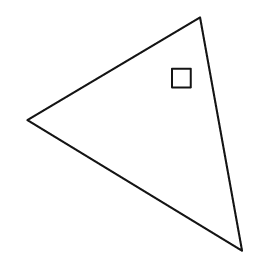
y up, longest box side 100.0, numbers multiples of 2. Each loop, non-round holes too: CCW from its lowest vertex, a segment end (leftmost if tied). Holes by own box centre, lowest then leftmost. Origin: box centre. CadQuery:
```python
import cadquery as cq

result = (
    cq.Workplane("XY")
    .moveTo(46.0, -50.0)
    .lineTo(28.0, 50.0)
    .lineTo(-46.0, 6.0)
    .close()
    .moveTo(16.0, 20.0)
    .lineTo(24.0, 20.0)
    .lineTo(24.0, 28.0)
    .lineTo(16.0, 28.0)
    .close()
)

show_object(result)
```